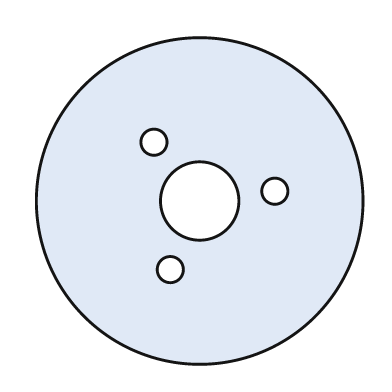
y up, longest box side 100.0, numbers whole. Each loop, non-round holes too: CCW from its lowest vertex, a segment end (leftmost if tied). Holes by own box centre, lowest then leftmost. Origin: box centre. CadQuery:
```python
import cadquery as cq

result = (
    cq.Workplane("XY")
    .moveTo(0.0, 0.0)
    .circle(50.0)
    .moveTo(-9.0, -21.0)
    .circle(4.0)
    .moveTo(0.0, 0.0)
    .circle(12.0)
    .moveTo(23.0, 3.0)
    .circle(4.0)
    .moveTo(-14.0, 18.0)
    .circle(4.0)
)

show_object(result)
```